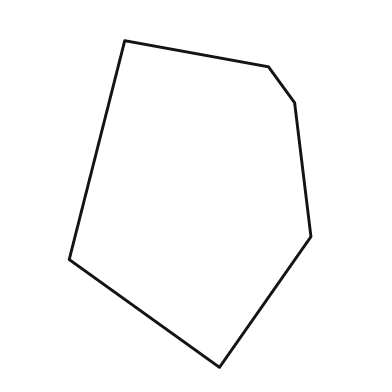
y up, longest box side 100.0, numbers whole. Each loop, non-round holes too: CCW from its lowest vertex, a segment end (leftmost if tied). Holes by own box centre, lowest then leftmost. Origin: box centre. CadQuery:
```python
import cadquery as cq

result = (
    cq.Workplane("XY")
    .moveTo(9.0, -50.0)
    .lineTo(37.0, -10.0)
    .lineTo(32.0, 31.0)
    .lineTo(24.0, 42.0)
    .lineTo(-20.0, 50.0)
    .lineTo(-37.0, -17.0)
    .close()
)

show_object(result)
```